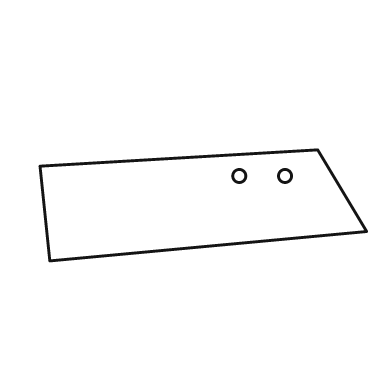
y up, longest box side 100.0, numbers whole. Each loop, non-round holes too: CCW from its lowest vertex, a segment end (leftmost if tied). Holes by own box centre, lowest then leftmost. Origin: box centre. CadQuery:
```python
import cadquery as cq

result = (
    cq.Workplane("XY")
    .moveTo(-47.0, -17.0)
    .lineTo(50.0, -8.0)
    .lineTo(35.0, 17.0)
    .lineTo(-50.0, 12.0)
    .close()
    .moveTo(11.0, 9.0)
    .circle(2.0)
    .moveTo(25.0, 9.0)
    .circle(2.0)
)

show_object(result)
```